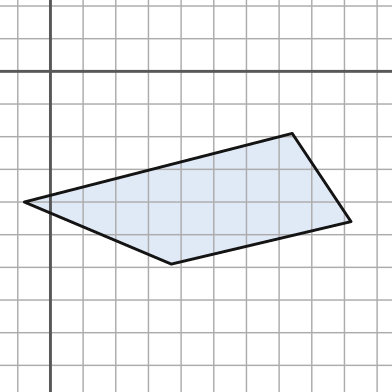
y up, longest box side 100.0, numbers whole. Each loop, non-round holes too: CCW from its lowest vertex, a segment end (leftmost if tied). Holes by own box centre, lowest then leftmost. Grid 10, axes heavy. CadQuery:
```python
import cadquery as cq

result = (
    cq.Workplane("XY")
    .moveTo(37.0, -59.0)
    .lineTo(92.0, -46.0)
    .lineTo(74.0, -19.0)
    .lineTo(-8.0, -40.0)
    .close()
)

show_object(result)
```